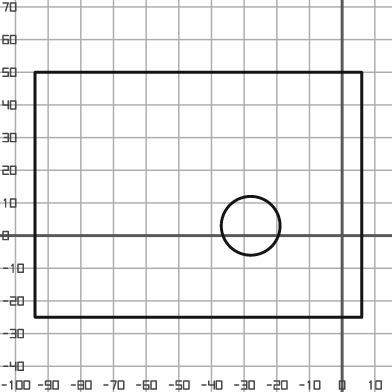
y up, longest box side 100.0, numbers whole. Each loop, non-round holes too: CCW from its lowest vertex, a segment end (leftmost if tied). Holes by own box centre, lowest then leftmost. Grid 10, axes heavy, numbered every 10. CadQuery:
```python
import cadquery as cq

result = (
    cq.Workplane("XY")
    .moveTo(-94.0, -25.0)
    .lineTo(6.0, -25.0)
    .lineTo(6.0, 50.0)
    .lineTo(-94.0, 50.0)
    .close()
    .moveTo(-28.0, 3.0)
    .circle(9.0)
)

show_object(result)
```